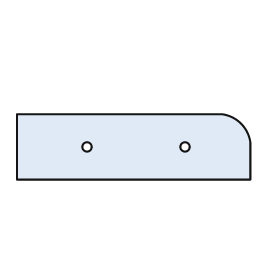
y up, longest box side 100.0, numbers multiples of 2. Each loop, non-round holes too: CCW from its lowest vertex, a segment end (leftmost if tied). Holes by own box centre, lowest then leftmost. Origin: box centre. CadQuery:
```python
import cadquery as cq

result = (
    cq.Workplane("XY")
    .moveTo(-50.0, -14.0)
    .lineTo(50.0, -14.0)
    .lineTo(50.0, 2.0)
    .threePointArc((46.0, 10.0), (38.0, 14.0))
    .lineTo(-50.0, 14.0)
    .close()
    .moveTo(-20.0, 0.0)
    .circle(2.0)
    .moveTo(22.0, 0.0)
    .circle(2.0)
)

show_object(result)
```